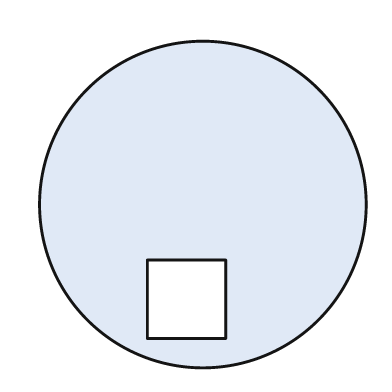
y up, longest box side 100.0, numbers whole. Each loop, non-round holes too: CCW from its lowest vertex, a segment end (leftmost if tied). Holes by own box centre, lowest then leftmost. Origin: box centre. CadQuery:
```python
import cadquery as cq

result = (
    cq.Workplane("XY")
    .moveTo(0.0, 0.0)
    .circle(50.0)
    .moveTo(-17.0, -41.0)
    .lineTo(7.0, -41.0)
    .lineTo(7.0, -17.0)
    .lineTo(-17.0, -17.0)
    .close()
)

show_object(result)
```